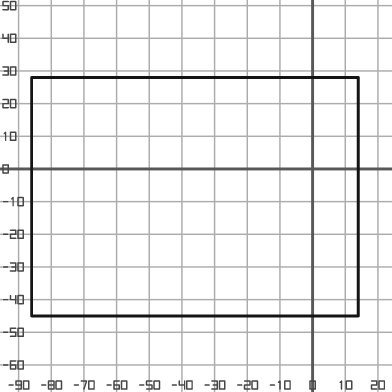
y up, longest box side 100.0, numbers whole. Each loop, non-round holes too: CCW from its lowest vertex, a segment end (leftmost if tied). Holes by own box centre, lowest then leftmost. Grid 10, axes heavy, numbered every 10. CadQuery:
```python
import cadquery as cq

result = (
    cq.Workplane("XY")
    .moveTo(-86.0, -45.0)
    .lineTo(14.0, -45.0)
    .lineTo(14.0, 28.0)
    .lineTo(-86.0, 28.0)
    .close()
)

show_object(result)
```